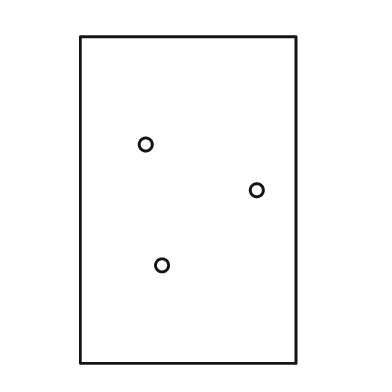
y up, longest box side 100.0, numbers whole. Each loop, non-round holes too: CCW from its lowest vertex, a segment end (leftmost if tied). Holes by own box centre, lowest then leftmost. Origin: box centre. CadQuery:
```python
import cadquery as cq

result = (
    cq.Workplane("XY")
    .moveTo(-33.0, -50.0)
    .lineTo(33.0, -50.0)
    .lineTo(33.0, 50.0)
    .lineTo(-33.0, 50.0)
    .close()
    .moveTo(-8.0, -20.0)
    .circle(2.0)
    .moveTo(21.0, 3.0)
    .circle(2.0)
    .moveTo(-13.0, 17.0)
    .circle(2.0)
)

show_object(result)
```